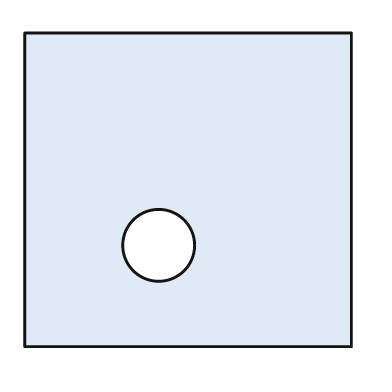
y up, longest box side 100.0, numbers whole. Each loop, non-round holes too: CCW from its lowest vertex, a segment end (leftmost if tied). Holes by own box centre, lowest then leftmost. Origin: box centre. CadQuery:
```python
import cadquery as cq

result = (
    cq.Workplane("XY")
    .moveTo(-50.0, -48.0)
    .lineTo(50.0, -48.0)
    .lineTo(50.0, 48.0)
    .lineTo(-50.0, 48.0)
    .close()
    .moveTo(-9.0, -17.0)
    .circle(11.0)
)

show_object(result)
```